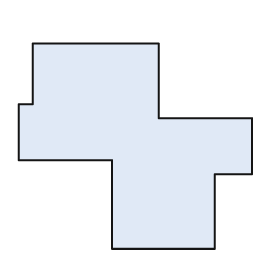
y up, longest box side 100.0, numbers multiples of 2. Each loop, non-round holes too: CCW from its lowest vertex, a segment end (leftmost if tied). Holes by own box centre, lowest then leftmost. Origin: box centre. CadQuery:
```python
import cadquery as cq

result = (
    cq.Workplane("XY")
    .moveTo(-10.0, -44.0)
    .lineTo(34.0, -44.0)
    .lineTo(34.0, -12.0)
    .lineTo(50.0, -12.0)
    .lineTo(50.0, 12.0)
    .lineTo(10.0, 12.0)
    .lineTo(10.0, 44.0)
    .lineTo(-44.0, 44.0)
    .lineTo(-44.0, 18.0)
    .lineTo(-50.0, 18.0)
    .lineTo(-50.0, -6.0)
    .lineTo(-10.0, -6.0)
    .close()
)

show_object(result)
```